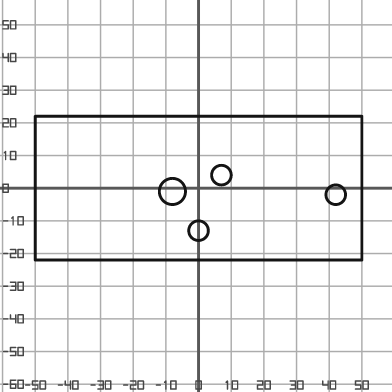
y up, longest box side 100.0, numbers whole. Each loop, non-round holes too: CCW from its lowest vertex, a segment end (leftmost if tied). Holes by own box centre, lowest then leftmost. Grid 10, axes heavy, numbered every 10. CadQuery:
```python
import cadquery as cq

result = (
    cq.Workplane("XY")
    .moveTo(-50.0, -22.0)
    .lineTo(50.0, -22.0)
    .lineTo(50.0, 22.0)
    .lineTo(-50.0, 22.0)
    .close()
    .moveTo(0.0, -13.0)
    .circle(3.0)
    .moveTo(42.0, -2.0)
    .circle(3.0)
    .moveTo(-8.0, -1.0)
    .circle(4.0)
    .moveTo(7.0, 4.0)
    .circle(3.0)
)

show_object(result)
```